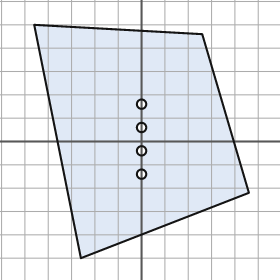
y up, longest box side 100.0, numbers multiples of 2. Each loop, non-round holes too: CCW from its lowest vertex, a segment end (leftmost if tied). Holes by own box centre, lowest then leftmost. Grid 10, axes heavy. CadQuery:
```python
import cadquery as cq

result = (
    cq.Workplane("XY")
    .moveTo(-26.0, -50.0)
    .lineTo(46.0, -22.0)
    .lineTo(26.0, 46.0)
    .lineTo(-46.0, 50.0)
    .close()
    .moveTo(0.0, -14.0)
    .circle(2.0)
    .moveTo(0.0, -4.0)
    .circle(2.0)
    .moveTo(0.0, 6.0)
    .circle(2.0)
    .moveTo(0.0, 16.0)
    .circle(2.0)
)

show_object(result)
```